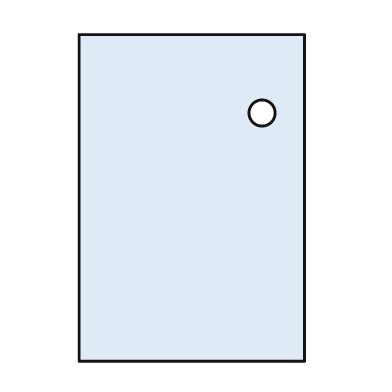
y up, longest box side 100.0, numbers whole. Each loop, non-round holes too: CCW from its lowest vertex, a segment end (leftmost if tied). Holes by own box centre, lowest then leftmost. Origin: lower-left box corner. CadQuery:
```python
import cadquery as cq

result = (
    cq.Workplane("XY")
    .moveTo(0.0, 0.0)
    .lineTo(69.0, 0.0)
    .lineTo(69.0, 100.0)
    .lineTo(0.0, 100.0)
    .close()
    .moveTo(56.0, 76.0)
    .circle(4.0)
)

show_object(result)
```